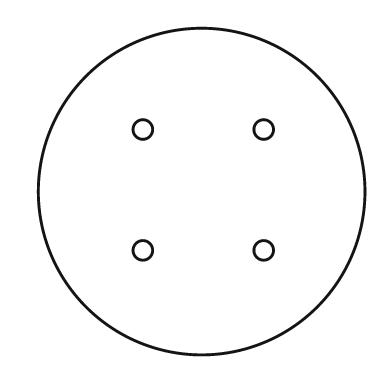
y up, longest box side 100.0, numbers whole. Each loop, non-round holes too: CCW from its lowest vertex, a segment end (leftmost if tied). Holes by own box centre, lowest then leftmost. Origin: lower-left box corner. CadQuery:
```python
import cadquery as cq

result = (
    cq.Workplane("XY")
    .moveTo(50.0, 50.0)
    .circle(50.0)
    .moveTo(32.0, 32.0)
    .circle(3.0)
    .moveTo(69.0, 32.0)
    .circle(3.0)
    .moveTo(32.0, 69.0)
    .circle(3.0)
    .moveTo(69.0, 69.0)
    .circle(3.0)
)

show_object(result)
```